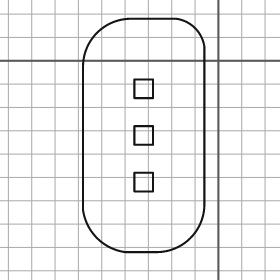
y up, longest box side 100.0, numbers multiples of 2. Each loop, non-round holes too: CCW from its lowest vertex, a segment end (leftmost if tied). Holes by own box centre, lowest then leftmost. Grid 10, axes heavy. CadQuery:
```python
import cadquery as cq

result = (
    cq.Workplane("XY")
    .moveTo(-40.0, -82.0)
    .lineTo(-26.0, -82.0)
    .threePointArc((-12.0, -76.0), (-6.0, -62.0))
    .lineTo(-6.0, 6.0)
    .threePointArc((-10.0, 14.0), (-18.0, 18.0))
    .lineTo(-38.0, 18.0)
    .threePointArc((-52.0, 12.0), (-58.0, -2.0))
    .lineTo(-58.0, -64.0)
    .threePointArc((-52.0, -76.0), (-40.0, -82.0))
    .close()
    .moveTo(-36.0, -56.0)
    .lineTo(-28.0, -56.0)
    .lineTo(-28.0, -48.0)
    .lineTo(-36.0, -48.0)
    .close()
    .moveTo(-36.0, -36.0)
    .lineTo(-28.0, -36.0)
    .lineTo(-28.0, -28.0)
    .lineTo(-36.0, -28.0)
    .close()
    .moveTo(-36.0, -16.0)
    .lineTo(-28.0, -16.0)
    .lineTo(-28.0, -8.0)
    .lineTo(-36.0, -8.0)
    .close()
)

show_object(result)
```